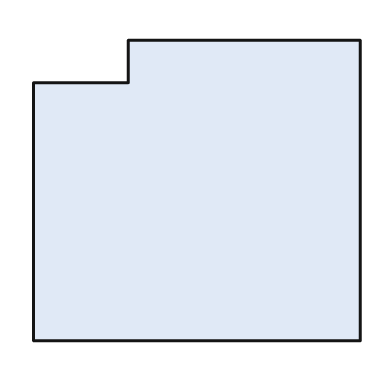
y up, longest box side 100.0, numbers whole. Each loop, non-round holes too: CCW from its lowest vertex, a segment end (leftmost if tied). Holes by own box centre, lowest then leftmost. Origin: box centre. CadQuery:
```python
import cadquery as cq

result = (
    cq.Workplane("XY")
    .moveTo(-50.0, -46.0)
    .lineTo(50.0, -46.0)
    .lineTo(50.0, 46.0)
    .lineTo(-21.0, 46.0)
    .lineTo(-21.0, 33.0)
    .lineTo(-50.0, 33.0)
    .close()
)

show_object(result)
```